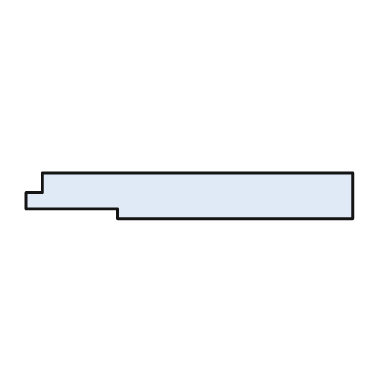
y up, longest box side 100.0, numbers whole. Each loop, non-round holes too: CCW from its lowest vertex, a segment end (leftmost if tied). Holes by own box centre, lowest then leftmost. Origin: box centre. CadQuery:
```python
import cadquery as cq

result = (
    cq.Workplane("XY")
    .moveTo(-22.0, -7.0)
    .lineTo(50.0, -7.0)
    .lineTo(50.0, 7.0)
    .lineTo(-45.0, 7.0)
    .lineTo(-45.0, 1.0)
    .lineTo(-50.0, 1.0)
    .lineTo(-50.0, -4.0)
    .lineTo(-22.0, -4.0)
    .close()
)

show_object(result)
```